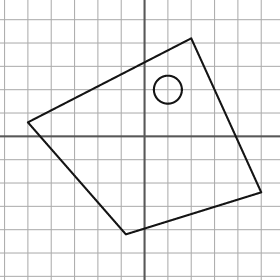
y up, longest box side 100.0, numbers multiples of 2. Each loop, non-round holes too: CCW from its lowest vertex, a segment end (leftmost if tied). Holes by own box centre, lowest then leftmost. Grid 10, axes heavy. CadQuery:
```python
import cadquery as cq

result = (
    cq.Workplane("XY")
    .moveTo(-8.0, -42.0)
    .lineTo(50.0, -24.0)
    .lineTo(20.0, 42.0)
    .lineTo(-50.0, 6.0)
    .close()
    .moveTo(10.0, 20.0)
    .circle(6.0)
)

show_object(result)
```